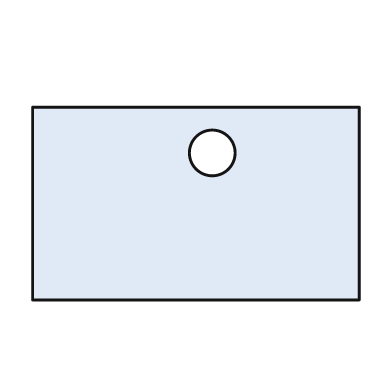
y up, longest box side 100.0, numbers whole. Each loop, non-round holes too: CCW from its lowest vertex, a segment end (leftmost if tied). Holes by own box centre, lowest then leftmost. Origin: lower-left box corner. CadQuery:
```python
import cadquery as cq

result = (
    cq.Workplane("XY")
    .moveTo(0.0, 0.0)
    .lineTo(100.0, 0.0)
    .lineTo(100.0, 59.0)
    .lineTo(0.0, 59.0)
    .close()
    .moveTo(55.0, 45.0)
    .circle(7.0)
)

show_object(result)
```